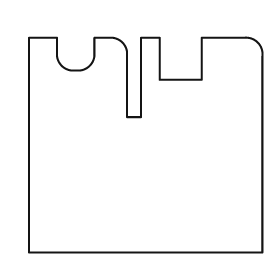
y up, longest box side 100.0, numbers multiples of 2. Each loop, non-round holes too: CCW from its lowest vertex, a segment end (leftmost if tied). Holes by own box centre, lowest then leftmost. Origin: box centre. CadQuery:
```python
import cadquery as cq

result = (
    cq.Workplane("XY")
    .moveTo(-50.0, -46.0)
    .lineTo(50.0, -46.0)
    .lineTo(50.0, 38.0)
    .threePointArc((48.0, 44.0), (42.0, 46.0))
    .lineTo(24.0, 46.0)
    .lineTo(24.0, 28.0)
    .lineTo(6.0, 28.0)
    .lineTo(6.0, 46.0)
    .lineTo(-2.0, 46.0)
    .lineTo(-2.0, 12.0)
    .lineTo(-8.0, 12.0)
    .lineTo(-8.0, 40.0)
    .threePointArc((-10.0, 44.0), (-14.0, 46.0))
    .lineTo(-22.0, 46.0)
    .lineTo(-22.0, 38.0)
    .threePointArc((-24.0, 34.0), (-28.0, 32.0))
    .lineTo(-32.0, 32.0)
    .threePointArc((-36.0, 34.0), (-38.0, 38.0))
    .lineTo(-38.0, 46.0)
    .lineTo(-50.0, 46.0)
    .close()
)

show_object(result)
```